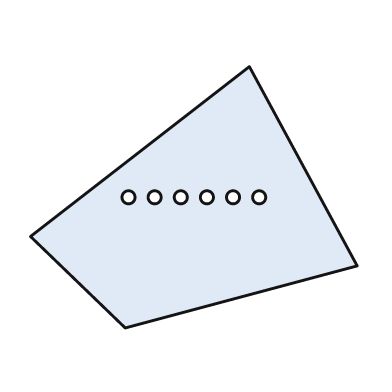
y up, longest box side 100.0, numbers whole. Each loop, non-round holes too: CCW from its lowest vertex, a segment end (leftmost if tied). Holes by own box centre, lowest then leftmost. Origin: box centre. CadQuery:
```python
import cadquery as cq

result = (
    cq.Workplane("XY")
    .moveTo(-21.0, -40.0)
    .lineTo(50.0, -21.0)
    .lineTo(17.0, 40.0)
    .lineTo(-50.0, -12.0)
    .close()
    .moveTo(-20.0, 0.0)
    .circle(2.0)
    .moveTo(-12.0, 0.0)
    .circle(2.0)
    .moveTo(-4.0, 0.0)
    .circle(2.0)
    .moveTo(4.0, 0.0)
    .circle(2.0)
    .moveTo(12.0, 0.0)
    .circle(2.0)
    .moveTo(20.0, 0.0)
    .circle(2.0)
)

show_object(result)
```